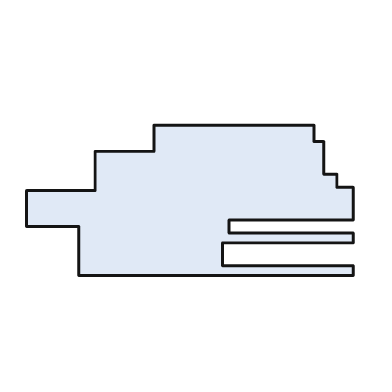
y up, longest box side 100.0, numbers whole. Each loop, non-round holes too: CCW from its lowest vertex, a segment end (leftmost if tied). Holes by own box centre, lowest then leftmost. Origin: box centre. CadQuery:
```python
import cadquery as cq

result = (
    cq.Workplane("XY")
    .moveTo(-34.0, -23.0)
    .lineTo(50.0, -23.0)
    .lineTo(50.0, -20.0)
    .lineTo(10.0, -20.0)
    .lineTo(10.0, -13.0)
    .lineTo(50.0, -13.0)
    .lineTo(50.0, -10.0)
    .lineTo(12.0, -10.0)
    .lineTo(12.0, -6.0)
    .lineTo(50.0, -6.0)
    .lineTo(50.0, 4.0)
    .lineTo(45.0, 4.0)
    .lineTo(45.0, 8.0)
    .lineTo(41.0, 8.0)
    .lineTo(41.0, 18.0)
    .lineTo(38.0, 18.0)
    .lineTo(38.0, 23.0)
    .lineTo(-11.0, 23.0)
    .lineTo(-11.0, 15.0)
    .lineTo(-29.0, 15.0)
    .lineTo(-29.0, 3.0)
    .lineTo(-50.0, 3.0)
    .lineTo(-50.0, -8.0)
    .lineTo(-34.0, -8.0)
    .close()
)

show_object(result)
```